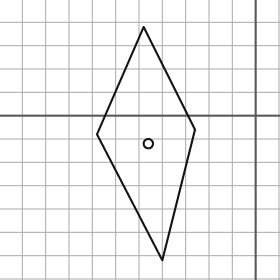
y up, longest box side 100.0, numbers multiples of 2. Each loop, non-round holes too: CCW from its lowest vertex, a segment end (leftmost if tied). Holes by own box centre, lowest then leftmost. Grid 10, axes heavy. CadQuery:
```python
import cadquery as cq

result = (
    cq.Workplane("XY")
    .moveTo(-40.0, -62.0)
    .lineTo(-26.0, -6.0)
    .lineTo(-48.0, 38.0)
    .lineTo(-68.0, -8.0)
    .close()
    .moveTo(-46.0, -12.0)
    .circle(2.0)
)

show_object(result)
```